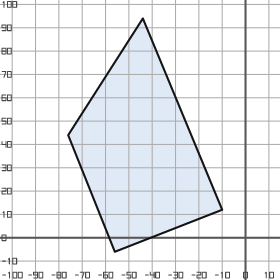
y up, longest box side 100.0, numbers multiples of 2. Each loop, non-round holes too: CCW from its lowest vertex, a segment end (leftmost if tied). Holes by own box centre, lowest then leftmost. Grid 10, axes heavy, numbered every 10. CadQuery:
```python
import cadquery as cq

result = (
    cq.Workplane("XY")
    .moveTo(-56.0, -6.0)
    .lineTo(-10.0, 12.0)
    .lineTo(-44.0, 94.0)
    .lineTo(-76.0, 44.0)
    .close()
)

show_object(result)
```